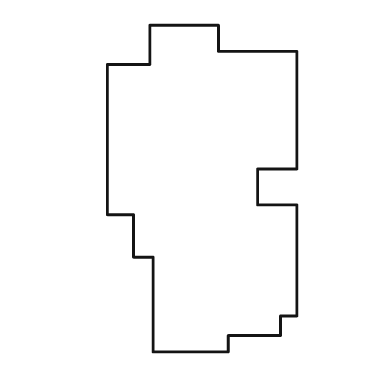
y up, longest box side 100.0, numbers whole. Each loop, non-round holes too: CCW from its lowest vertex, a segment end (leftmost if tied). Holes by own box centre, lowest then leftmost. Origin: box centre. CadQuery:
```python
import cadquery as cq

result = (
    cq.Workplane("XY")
    .moveTo(-15.0, -50.0)
    .lineTo(8.0, -50.0)
    .lineTo(8.0, -45.0)
    .lineTo(24.0, -45.0)
    .lineTo(24.0, -39.0)
    .lineTo(29.0, -39.0)
    .lineTo(29.0, -5.0)
    .lineTo(17.0, -5.0)
    .lineTo(17.0, 6.0)
    .lineTo(29.0, 6.0)
    .lineTo(29.0, 42.0)
    .lineTo(5.0, 42.0)
    .lineTo(5.0, 50.0)
    .lineTo(-16.0, 50.0)
    .lineTo(-16.0, 38.0)
    .lineTo(-29.0, 38.0)
    .lineTo(-29.0, -8.0)
    .lineTo(-21.0, -8.0)
    .lineTo(-21.0, -21.0)
    .lineTo(-15.0, -21.0)
    .close()
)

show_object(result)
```